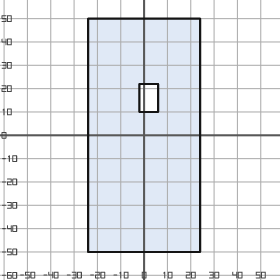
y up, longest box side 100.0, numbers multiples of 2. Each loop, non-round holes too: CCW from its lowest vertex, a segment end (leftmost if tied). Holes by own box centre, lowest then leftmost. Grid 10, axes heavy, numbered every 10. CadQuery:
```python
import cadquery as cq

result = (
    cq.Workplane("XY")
    .moveTo(-24.0, -50.0)
    .lineTo(24.0, -50.0)
    .lineTo(24.0, 50.0)
    .lineTo(-24.0, 50.0)
    .close()
    .moveTo(-2.0, 10.0)
    .lineTo(6.0, 10.0)
    .lineTo(6.0, 22.0)
    .lineTo(-2.0, 22.0)
    .close()
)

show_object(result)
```